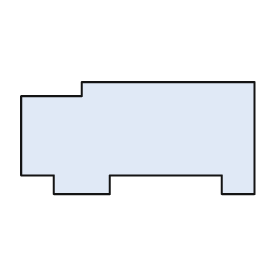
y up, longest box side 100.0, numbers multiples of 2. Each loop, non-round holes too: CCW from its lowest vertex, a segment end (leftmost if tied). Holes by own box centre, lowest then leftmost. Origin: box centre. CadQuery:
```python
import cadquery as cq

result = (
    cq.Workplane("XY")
    .moveTo(-36.0, -24.0)
    .lineTo(-12.0, -24.0)
    .lineTo(-12.0, -16.0)
    .lineTo(36.0, -16.0)
    .lineTo(36.0, -24.0)
    .lineTo(50.0, -24.0)
    .lineTo(50.0, 24.0)
    .lineTo(-24.0, 24.0)
    .lineTo(-24.0, 18.0)
    .lineTo(-50.0, 18.0)
    .lineTo(-50.0, -16.0)
    .lineTo(-36.0, -16.0)
    .close()
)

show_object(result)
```